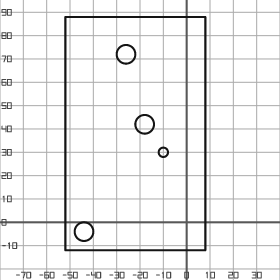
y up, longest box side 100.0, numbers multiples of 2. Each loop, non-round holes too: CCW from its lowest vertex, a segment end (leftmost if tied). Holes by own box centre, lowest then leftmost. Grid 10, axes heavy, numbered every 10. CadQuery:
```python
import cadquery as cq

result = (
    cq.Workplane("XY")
    .moveTo(-52.0, -12.0)
    .lineTo(8.0, -12.0)
    .lineTo(8.0, 88.0)
    .lineTo(-52.0, 88.0)
    .close()
    .moveTo(-44.0, -4.0)
    .circle(4.0)
    .moveTo(-10.0, 30.0)
    .circle(2.0)
    .moveTo(-18.0, 42.0)
    .circle(4.0)
    .moveTo(-26.0, 72.0)
    .circle(4.0)
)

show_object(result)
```